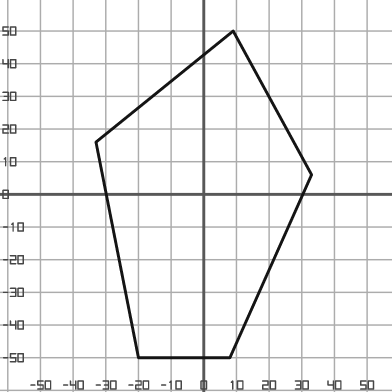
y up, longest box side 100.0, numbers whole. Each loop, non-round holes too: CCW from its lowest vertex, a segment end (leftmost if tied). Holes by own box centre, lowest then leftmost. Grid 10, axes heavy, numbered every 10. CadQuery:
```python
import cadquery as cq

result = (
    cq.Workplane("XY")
    .moveTo(-20.0, -50.0)
    .lineTo(8.0, -50.0)
    .lineTo(33.0, 6.0)
    .lineTo(9.0, 50.0)
    .lineTo(-33.0, 16.0)
    .close()
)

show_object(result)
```